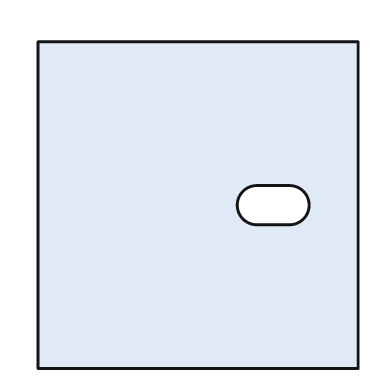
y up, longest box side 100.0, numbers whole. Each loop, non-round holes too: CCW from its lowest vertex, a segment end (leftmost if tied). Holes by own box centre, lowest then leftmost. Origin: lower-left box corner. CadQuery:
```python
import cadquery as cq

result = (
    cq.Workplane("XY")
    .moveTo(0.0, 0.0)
    .lineTo(98.0, 0.0)
    .lineTo(98.0, 100.0)
    .lineTo(0.0, 100.0)
    .close()
    .moveTo(67.0, 44.0)
    .lineTo(77.0, 44.0)
    .threePointArc((83.0, 50.0), (77.0, 56.0))
    .lineTo(67.0, 56.0)
    .threePointArc((61.0, 50.0), (67.0, 44.0))
    .close()
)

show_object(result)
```